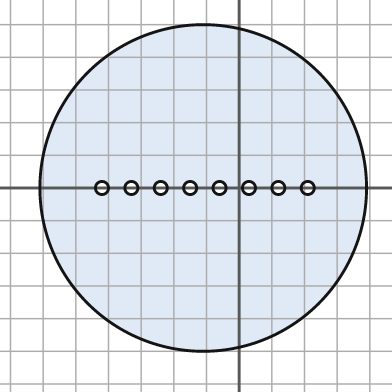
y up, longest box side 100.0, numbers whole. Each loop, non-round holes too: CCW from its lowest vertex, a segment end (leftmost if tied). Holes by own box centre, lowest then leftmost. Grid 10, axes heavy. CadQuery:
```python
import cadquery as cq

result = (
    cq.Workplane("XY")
    .moveTo(-11.0, 0.0)
    .circle(50.0)
    .moveTo(-42.0, 0.0)
    .circle(2.0)
    .moveTo(-33.0, 0.0)
    .circle(2.0)
    .moveTo(-24.0, 0.0)
    .circle(2.0)
    .moveTo(-15.0, 0.0)
    .circle(2.0)
    .moveTo(-6.0, 0.0)
    .circle(2.0)
    .moveTo(3.0, 0.0)
    .circle(2.0)
    .moveTo(12.0, 0.0)
    .circle(2.0)
    .moveTo(21.0, 0.0)
    .circle(2.0)
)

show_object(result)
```